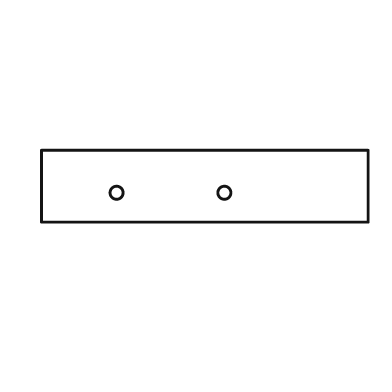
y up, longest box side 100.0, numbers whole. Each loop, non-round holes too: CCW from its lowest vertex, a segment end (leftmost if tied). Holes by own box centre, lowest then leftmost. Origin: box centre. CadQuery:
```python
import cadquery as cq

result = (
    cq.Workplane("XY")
    .moveTo(-50.0, -11.0)
    .lineTo(50.0, -11.0)
    .lineTo(50.0, 11.0)
    .lineTo(-50.0, 11.0)
    .close()
    .moveTo(-27.0, -2.0)
    .circle(2.0)
    .moveTo(6.0, -2.0)
    .circle(2.0)
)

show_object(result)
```